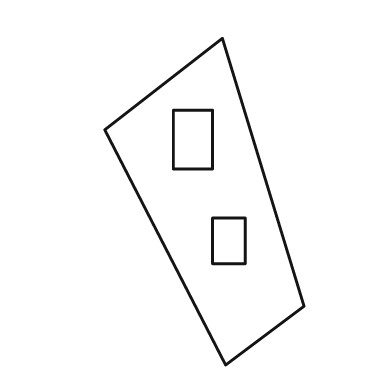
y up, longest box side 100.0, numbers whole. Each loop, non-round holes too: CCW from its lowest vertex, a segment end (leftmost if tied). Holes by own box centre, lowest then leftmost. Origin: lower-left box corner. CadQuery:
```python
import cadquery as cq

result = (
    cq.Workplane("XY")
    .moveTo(37.0, 0.0)
    .lineTo(61.0, 18.0)
    .lineTo(36.0, 100.0)
    .lineTo(0.0, 72.0)
    .close()
    .moveTo(33.0, 31.0)
    .lineTo(43.0, 31.0)
    .lineTo(43.0, 45.0)
    .lineTo(33.0, 45.0)
    .close()
    .moveTo(21.0, 60.0)
    .lineTo(33.0, 60.0)
    .lineTo(33.0, 78.0)
    .lineTo(21.0, 78.0)
    .close()
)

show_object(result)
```